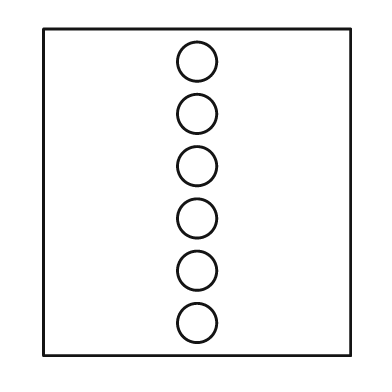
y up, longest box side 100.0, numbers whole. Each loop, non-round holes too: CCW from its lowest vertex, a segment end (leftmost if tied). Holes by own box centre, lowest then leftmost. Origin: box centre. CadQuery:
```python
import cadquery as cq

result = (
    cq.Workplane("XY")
    .moveTo(-47.0, -50.0)
    .lineTo(47.0, -50.0)
    .lineTo(47.0, 50.0)
    .lineTo(-47.0, 50.0)
    .close()
    .moveTo(0.0, -40.0)
    .circle(6.0)
    .moveTo(0.0, -24.0)
    .circle(6.0)
    .moveTo(0.0, -8.0)
    .circle(6.0)
    .moveTo(0.0, 8.0)
    .circle(6.0)
    .moveTo(0.0, 24.0)
    .circle(6.0)
    .moveTo(0.0, 40.0)
    .circle(6.0)
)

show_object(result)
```